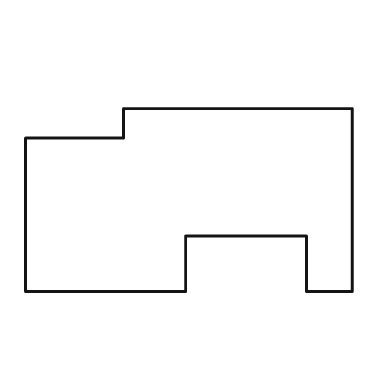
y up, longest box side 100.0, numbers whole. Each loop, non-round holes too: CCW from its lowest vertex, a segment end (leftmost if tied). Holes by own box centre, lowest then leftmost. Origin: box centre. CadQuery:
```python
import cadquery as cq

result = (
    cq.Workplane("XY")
    .moveTo(-50.0, -28.0)
    .lineTo(-1.0, -28.0)
    .lineTo(-1.0, -11.0)
    .lineTo(36.0, -11.0)
    .lineTo(36.0, -28.0)
    .lineTo(50.0, -28.0)
    .lineTo(50.0, 28.0)
    .lineTo(-20.0, 28.0)
    .lineTo(-20.0, 19.0)
    .lineTo(-50.0, 19.0)
    .close()
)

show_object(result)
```